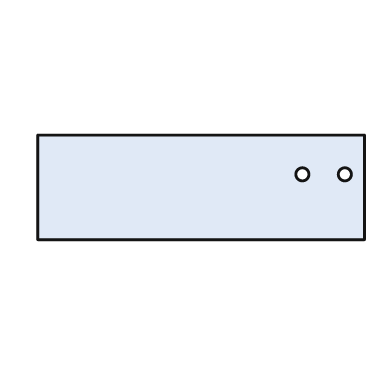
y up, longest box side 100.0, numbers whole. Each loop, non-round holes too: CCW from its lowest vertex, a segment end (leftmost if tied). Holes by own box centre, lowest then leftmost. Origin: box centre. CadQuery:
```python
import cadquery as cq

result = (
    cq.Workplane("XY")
    .moveTo(-50.0, -16.0)
    .lineTo(50.0, -16.0)
    .lineTo(50.0, 16.0)
    .lineTo(-50.0, 16.0)
    .close()
    .moveTo(31.0, 4.0)
    .circle(2.0)
    .moveTo(44.0, 4.0)
    .circle(2.0)
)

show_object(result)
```